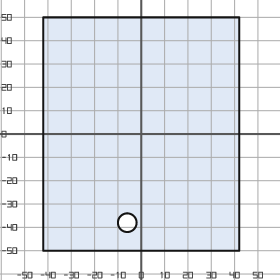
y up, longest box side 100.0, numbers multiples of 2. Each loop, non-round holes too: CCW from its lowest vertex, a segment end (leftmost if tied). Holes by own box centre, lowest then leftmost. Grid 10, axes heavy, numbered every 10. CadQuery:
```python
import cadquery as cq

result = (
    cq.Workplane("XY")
    .moveTo(-42.0, -50.0)
    .lineTo(42.0, -50.0)
    .lineTo(42.0, 50.0)
    .lineTo(-42.0, 50.0)
    .close()
    .moveTo(-6.0, -38.0)
    .circle(4.0)
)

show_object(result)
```